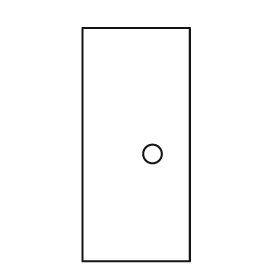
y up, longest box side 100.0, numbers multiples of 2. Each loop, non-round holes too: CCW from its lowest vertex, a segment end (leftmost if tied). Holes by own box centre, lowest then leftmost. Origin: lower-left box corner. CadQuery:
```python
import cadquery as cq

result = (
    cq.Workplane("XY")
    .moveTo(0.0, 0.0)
    .lineTo(46.0, 0.0)
    .lineTo(46.0, 100.0)
    .lineTo(0.0, 100.0)
    .close()
    .moveTo(30.0, 46.0)
    .circle(4.0)
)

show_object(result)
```